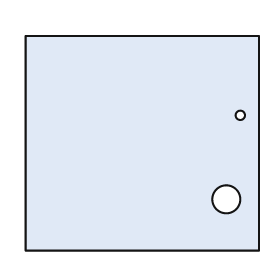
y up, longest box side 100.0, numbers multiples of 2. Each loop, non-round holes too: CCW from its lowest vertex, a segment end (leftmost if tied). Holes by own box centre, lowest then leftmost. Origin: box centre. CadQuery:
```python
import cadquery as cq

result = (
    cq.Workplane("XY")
    .moveTo(-50.0, -46.0)
    .lineTo(50.0, -46.0)
    .lineTo(50.0, 46.0)
    .lineTo(-50.0, 46.0)
    .close()
    .moveTo(36.0, -24.0)
    .circle(6.0)
    .moveTo(42.0, 12.0)
    .circle(2.0)
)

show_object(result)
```